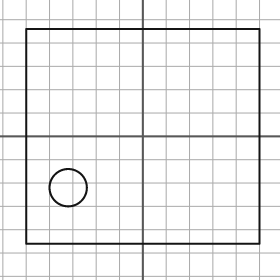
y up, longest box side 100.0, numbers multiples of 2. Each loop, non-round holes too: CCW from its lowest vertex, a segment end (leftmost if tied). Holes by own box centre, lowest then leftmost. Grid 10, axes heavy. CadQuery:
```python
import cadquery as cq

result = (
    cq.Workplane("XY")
    .moveTo(-50.0, -46.0)
    .lineTo(50.0, -46.0)
    .lineTo(50.0, 46.0)
    .lineTo(-50.0, 46.0)
    .close()
    .moveTo(-32.0, -22.0)
    .circle(8.0)
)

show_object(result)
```